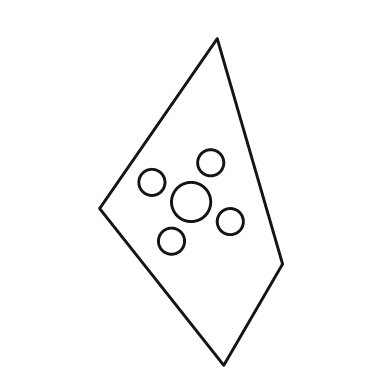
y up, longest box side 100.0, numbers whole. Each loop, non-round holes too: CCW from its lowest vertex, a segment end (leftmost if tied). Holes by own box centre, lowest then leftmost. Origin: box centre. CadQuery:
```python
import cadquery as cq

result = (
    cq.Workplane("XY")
    .moveTo(10.0, -50.0)
    .lineTo(28.0, -19.0)
    .lineTo(8.0, 50.0)
    .lineTo(-28.0, -2.0)
    .close()
    .moveTo(-6.0, -12.0)
    .circle(4.0)
    .moveTo(12.0, -6.0)
    .circle(4.0)
    .moveTo(0.0, 0.0)
    .circle(6.0)
    .moveTo(-12.0, 6.0)
    .circle(4.0)
    .moveTo(6.0, 12.0)
    .circle(4.0)
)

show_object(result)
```